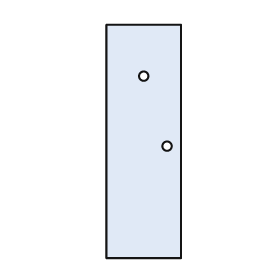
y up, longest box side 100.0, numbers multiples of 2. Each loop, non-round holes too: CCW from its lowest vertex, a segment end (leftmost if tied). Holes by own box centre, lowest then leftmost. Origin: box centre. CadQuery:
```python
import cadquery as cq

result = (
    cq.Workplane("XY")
    .moveTo(-16.0, -50.0)
    .lineTo(16.0, -50.0)
    .lineTo(16.0, 50.0)
    .lineTo(-16.0, 50.0)
    .close()
    .moveTo(10.0, -2.0)
    .circle(2.0)
    .moveTo(0.0, 28.0)
    .circle(2.0)
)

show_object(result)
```